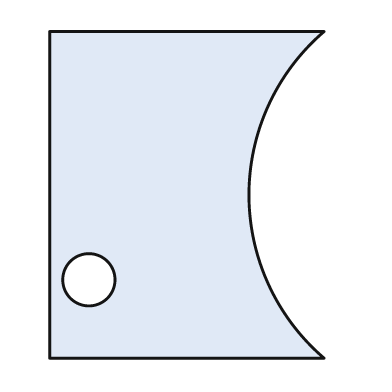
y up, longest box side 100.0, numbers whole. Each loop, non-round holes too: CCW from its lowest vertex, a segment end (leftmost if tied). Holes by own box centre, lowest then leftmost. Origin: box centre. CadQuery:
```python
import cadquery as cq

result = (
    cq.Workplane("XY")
    .moveTo(-42.0, -50.0)
    .lineTo(42.0, -50.0)
    .threePointArc((19.0, 0.0), (42.0, 50.0))
    .lineTo(-42.0, 50.0)
    .close()
    .moveTo(-30.0, -26.0)
    .circle(8.0)
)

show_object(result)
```